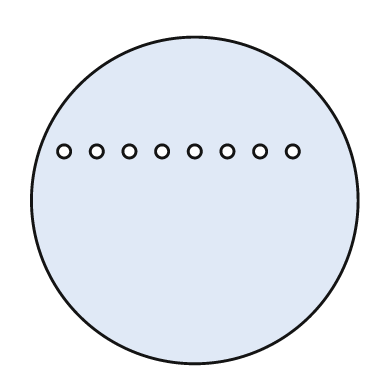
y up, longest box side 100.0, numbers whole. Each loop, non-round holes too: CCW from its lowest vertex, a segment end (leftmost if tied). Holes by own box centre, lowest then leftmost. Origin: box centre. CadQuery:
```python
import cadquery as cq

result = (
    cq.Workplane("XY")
    .moveTo(0.0, 0.0)
    .circle(50.0)
    .moveTo(-40.0, 15.0)
    .circle(2.0)
    .moveTo(-30.0, 15.0)
    .circle(2.0)
    .moveTo(-20.0, 15.0)
    .circle(2.0)
    .moveTo(-10.0, 15.0)
    .circle(2.0)
    .moveTo(0.0, 15.0)
    .circle(2.0)
    .moveTo(10.0, 15.0)
    .circle(2.0)
    .moveTo(20.0, 15.0)
    .circle(2.0)
    .moveTo(30.0, 15.0)
    .circle(2.0)
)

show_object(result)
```